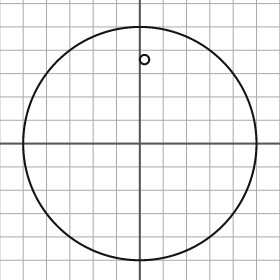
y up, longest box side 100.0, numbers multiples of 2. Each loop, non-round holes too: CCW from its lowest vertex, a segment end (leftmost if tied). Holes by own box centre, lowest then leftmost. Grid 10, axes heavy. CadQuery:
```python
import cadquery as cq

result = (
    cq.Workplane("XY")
    .moveTo(0.0, 0.0)
    .circle(50.0)
    .moveTo(2.0, 36.0)
    .circle(2.0)
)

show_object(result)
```